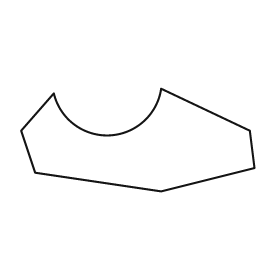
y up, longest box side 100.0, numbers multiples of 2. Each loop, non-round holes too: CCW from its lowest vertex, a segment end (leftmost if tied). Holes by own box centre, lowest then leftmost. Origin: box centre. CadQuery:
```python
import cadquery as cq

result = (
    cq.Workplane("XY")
    .moveTo(10.0, -22.0)
    .lineTo(50.0, -12.0)
    .lineTo(48.0, 4.0)
    .lineTo(10.0, 22.0)
    .threePointArc((-12.0, 2.0), (-36.0, 20.0))
    .lineTo(-50.0, 4.0)
    .lineTo(-44.0, -14.0)
    .close()
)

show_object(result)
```